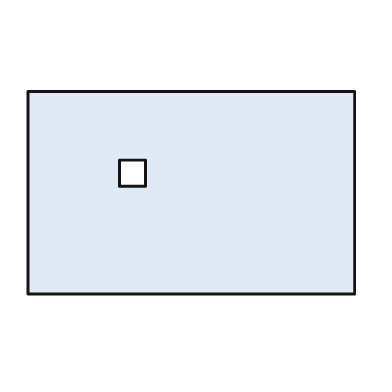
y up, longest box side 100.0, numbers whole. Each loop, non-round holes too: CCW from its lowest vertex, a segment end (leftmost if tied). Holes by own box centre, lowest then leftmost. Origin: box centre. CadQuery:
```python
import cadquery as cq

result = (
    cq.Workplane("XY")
    .moveTo(-50.0, -31.0)
    .lineTo(50.0, -31.0)
    .lineTo(50.0, 31.0)
    .lineTo(-50.0, 31.0)
    .close()
    .moveTo(-22.0, 2.0)
    .lineTo(-14.0, 2.0)
    .lineTo(-14.0, 10.0)
    .lineTo(-22.0, 10.0)
    .close()
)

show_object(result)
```